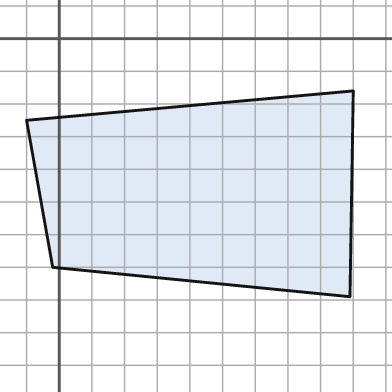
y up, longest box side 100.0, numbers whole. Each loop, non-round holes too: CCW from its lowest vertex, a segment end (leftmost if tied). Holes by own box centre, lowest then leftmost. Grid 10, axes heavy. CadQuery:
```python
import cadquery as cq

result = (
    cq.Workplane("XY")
    .moveTo(89.0, -79.0)
    .lineTo(90.0, -16.0)
    .lineTo(-10.0, -25.0)
    .lineTo(-2.0, -70.0)
    .close()
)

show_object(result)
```